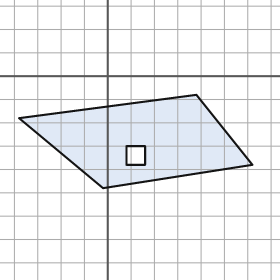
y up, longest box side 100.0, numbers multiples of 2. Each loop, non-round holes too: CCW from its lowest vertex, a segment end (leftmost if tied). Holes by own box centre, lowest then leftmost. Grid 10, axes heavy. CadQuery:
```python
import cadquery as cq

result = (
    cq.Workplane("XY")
    .moveTo(-2.0, -48.0)
    .lineTo(62.0, -38.0)
    .lineTo(38.0, -8.0)
    .lineTo(-38.0, -18.0)
    .close()
    .moveTo(8.0, -38.0)
    .lineTo(16.0, -38.0)
    .lineTo(16.0, -30.0)
    .lineTo(8.0, -30.0)
    .close()
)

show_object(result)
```